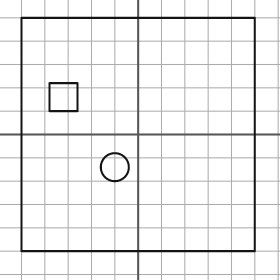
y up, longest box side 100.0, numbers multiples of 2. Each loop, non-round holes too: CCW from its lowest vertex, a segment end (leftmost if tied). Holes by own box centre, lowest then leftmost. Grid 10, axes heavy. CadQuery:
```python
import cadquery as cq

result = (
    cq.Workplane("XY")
    .moveTo(-50.0, -50.0)
    .lineTo(50.0, -50.0)
    .lineTo(50.0, 50.0)
    .lineTo(-50.0, 50.0)
    .close()
    .moveTo(-10.0, -14.0)
    .circle(6.0)
    .moveTo(-38.0, 10.0)
    .lineTo(-26.0, 10.0)
    .lineTo(-26.0, 22.0)
    .lineTo(-38.0, 22.0)
    .close()
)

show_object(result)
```